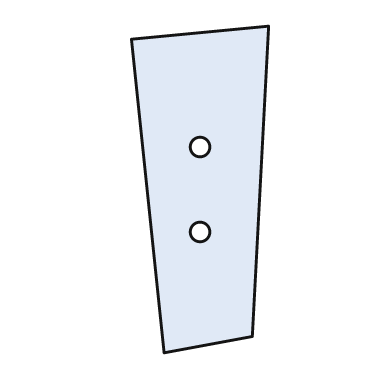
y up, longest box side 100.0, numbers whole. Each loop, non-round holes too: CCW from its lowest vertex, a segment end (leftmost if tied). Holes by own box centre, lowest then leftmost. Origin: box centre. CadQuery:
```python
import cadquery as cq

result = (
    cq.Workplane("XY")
    .moveTo(-11.0, -50.0)
    .lineTo(16.0, -45.0)
    .lineTo(21.0, 50.0)
    .lineTo(-21.0, 46.0)
    .close()
    .moveTo(0.0, -13.0)
    .circle(3.0)
    .moveTo(0.0, 13.0)
    .circle(3.0)
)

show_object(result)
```